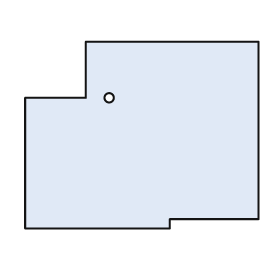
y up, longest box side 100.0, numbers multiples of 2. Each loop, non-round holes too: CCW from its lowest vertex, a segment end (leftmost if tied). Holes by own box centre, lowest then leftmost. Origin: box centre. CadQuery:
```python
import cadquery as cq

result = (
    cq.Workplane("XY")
    .moveTo(-50.0, -40.0)
    .lineTo(12.0, -40.0)
    .lineTo(12.0, -36.0)
    .lineTo(50.0, -36.0)
    .lineTo(50.0, 40.0)
    .lineTo(-24.0, 40.0)
    .lineTo(-24.0, 16.0)
    .lineTo(-50.0, 16.0)
    .close()
    .moveTo(-14.0, 16.0)
    .circle(2.0)
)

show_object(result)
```